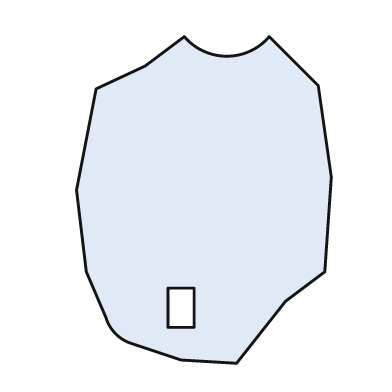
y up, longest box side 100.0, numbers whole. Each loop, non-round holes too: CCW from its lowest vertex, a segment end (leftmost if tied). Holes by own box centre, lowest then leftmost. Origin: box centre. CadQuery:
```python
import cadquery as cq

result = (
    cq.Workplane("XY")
    .moveTo(10.0, -50.0)
    .lineTo(25.0, -31.0)
    .lineTo(37.0, -22.0)
    .lineTo(39.0, 7.0)
    .lineTo(35.0, 35.0)
    .lineTo(20.0, 50.0)
    .threePointArc((7.0, 44.0), (-6.0, 50.0))
    .lineTo(-18.0, 41.0)
    .lineTo(-33.0, 34.0)
    .lineTo(-39.0, 3.0)
    .lineTo(-36.0, -22.0)
    .lineTo(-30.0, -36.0)
    .threePointArc((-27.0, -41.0), (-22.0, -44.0))
    .lineTo(-7.0, -49.0)
    .close()
    .moveTo(-11.0, -39.0)
    .lineTo(-3.0, -39.0)
    .lineTo(-3.0, -27.0)
    .lineTo(-11.0, -27.0)
    .close()
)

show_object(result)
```